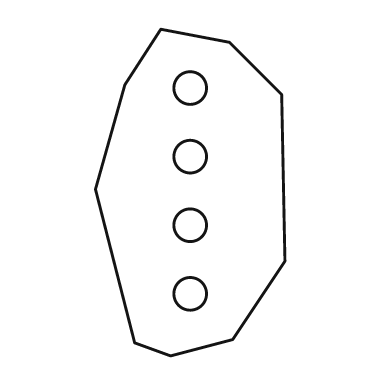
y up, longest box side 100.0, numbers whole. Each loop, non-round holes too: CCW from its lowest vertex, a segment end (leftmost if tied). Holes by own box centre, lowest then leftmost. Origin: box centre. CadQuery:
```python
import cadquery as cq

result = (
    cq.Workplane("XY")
    .moveTo(-6.0, -50.0)
    .lineTo(13.0, -45.0)
    .lineTo(29.0, -21.0)
    .lineTo(28.0, 30.0)
    .lineTo(12.0, 46.0)
    .lineTo(-9.0, 50.0)
    .lineTo(-20.0, 33.0)
    .lineTo(-29.0, 1.0)
    .lineTo(-17.0, -46.0)
    .close()
    .moveTo(0.0, -31.0)
    .circle(5.0)
    .moveTo(0.0, -10.0)
    .circle(5.0)
    .moveTo(0.0, 11.0)
    .circle(5.0)
    .moveTo(0.0, 32.0)
    .circle(5.0)
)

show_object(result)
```